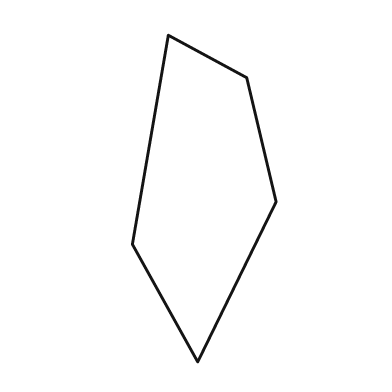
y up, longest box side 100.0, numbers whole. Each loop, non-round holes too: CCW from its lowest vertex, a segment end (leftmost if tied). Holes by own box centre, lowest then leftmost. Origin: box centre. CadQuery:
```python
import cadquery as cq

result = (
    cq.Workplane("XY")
    .moveTo(-2.0, -50.0)
    .lineTo(22.0, -1.0)
    .lineTo(13.0, 37.0)
    .lineTo(-11.0, 50.0)
    .lineTo(-22.0, -14.0)
    .close()
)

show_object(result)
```